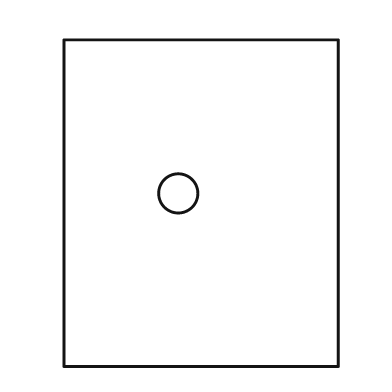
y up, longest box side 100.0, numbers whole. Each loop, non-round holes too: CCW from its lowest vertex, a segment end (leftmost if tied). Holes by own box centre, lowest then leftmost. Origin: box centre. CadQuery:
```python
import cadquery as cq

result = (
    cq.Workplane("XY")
    .moveTo(-42.0, -50.0)
    .lineTo(42.0, -50.0)
    .lineTo(42.0, 50.0)
    .lineTo(-42.0, 50.0)
    .close()
    .moveTo(-7.0, 3.0)
    .circle(6.0)
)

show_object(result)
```